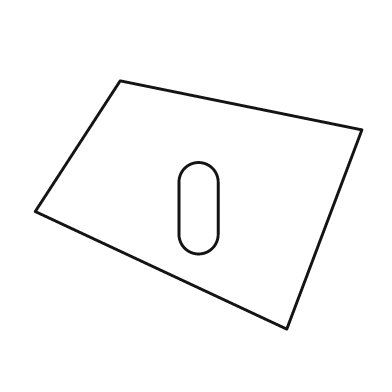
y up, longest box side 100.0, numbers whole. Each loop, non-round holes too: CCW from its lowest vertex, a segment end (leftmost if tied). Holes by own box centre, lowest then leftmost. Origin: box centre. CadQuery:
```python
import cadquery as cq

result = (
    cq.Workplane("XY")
    .moveTo(27.0, -38.0)
    .lineTo(50.0, 23.0)
    .lineTo(-24.0, 38.0)
    .lineTo(-50.0, -2.0)
    .close()
    .moveTo(-6.0, -9.0)
    .threePointArc((0.0, -15.0), (6.0, -9.0))
    .lineTo(6.0, 7.0)
    .threePointArc((0.0, 13.0), (-6.0, 7.0))
    .close()
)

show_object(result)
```